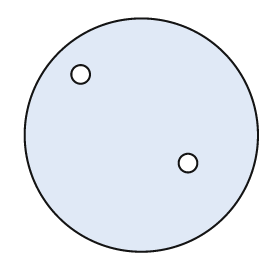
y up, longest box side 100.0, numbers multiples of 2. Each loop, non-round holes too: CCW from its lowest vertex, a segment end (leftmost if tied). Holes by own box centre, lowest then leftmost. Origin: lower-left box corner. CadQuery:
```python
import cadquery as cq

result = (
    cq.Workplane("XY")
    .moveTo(50.0, 50.0)
    .circle(50.0)
    .moveTo(70.0, 38.0)
    .circle(4.0)
    .moveTo(24.0, 76.0)
    .circle(4.0)
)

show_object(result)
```